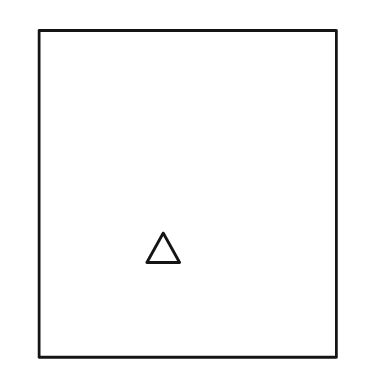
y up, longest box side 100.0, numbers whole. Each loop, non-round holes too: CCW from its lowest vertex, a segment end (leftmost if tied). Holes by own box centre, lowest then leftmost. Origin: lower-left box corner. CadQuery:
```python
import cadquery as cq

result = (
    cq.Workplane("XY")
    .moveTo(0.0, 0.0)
    .lineTo(91.0, 0.0)
    .lineTo(91.0, 100.0)
    .lineTo(0.0, 100.0)
    .close()
    .moveTo(33.0, 29.0)
    .lineTo(43.0, 29.0)
    .lineTo(38.0, 38.0)
    .close()
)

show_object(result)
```